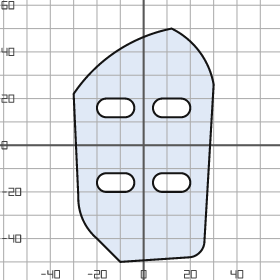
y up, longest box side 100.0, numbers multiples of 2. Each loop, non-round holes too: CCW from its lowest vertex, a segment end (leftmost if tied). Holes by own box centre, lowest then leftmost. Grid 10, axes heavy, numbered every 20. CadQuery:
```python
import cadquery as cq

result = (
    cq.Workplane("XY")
    .moveTo(-10.0, -50.0)
    .lineTo(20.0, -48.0)
    .threePointArc((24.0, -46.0), (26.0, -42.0))
    .lineTo(30.0, 26.0)
    .threePointArc((24.0, 40.0), (12.0, 50.0))
    .threePointArc((-12.0, 40.0), (-30.0, 22.0))
    .lineTo(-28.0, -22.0)
    .threePointArc((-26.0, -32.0), (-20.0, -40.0))
    .close()
    .moveTo(-16.0, -20.0)
    .lineTo(-8.0, -20.0)
    .threePointArc((-4.0, -16.0), (-8.0, -12.0))
    .lineTo(-16.0, -12.0)
    .threePointArc((-20.0, -16.0), (-16.0, -20.0))
    .close()
    .moveTo(8.0, -20.0)
    .lineTo(16.0, -20.0)
    .threePointArc((20.0, -16.0), (16.0, -12.0))
    .lineTo(8.0, -12.0)
    .threePointArc((4.0, -16.0), (8.0, -20.0))
    .close()
    .moveTo(-16.0, 12.0)
    .lineTo(-8.0, 12.0)
    .threePointArc((-4.0, 16.0), (-8.0, 20.0))
    .lineTo(-16.0, 20.0)
    .threePointArc((-20.0, 16.0), (-16.0, 12.0))
    .close()
    .moveTo(8.0, 12.0)
    .lineTo(16.0, 12.0)
    .threePointArc((20.0, 16.0), (16.0, 20.0))
    .lineTo(8.0, 20.0)
    .threePointArc((4.0, 16.0), (8.0, 12.0))
    .close()
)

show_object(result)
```